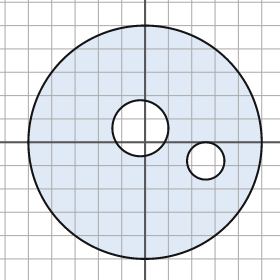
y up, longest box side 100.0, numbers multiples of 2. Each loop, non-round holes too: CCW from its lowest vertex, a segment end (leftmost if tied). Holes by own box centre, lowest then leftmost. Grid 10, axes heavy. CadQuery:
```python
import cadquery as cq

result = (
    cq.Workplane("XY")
    .moveTo(0.0, 0.0)
    .circle(50.0)
    .moveTo(26.0, -8.0)
    .circle(8.0)
    .moveTo(-2.0, 6.0)
    .circle(12.0)
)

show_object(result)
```